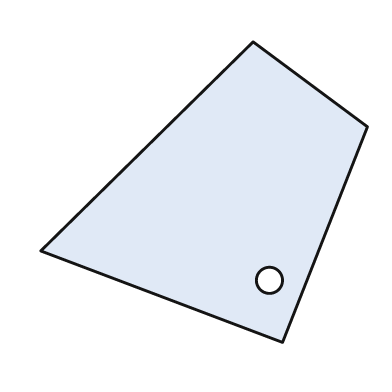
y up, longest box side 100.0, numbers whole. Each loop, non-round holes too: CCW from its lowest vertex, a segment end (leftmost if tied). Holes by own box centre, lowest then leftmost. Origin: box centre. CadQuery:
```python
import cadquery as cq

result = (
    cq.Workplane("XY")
    .moveTo(24.0, -46.0)
    .lineTo(50.0, 20.0)
    .lineTo(15.0, 46.0)
    .lineTo(-50.0, -18.0)
    .close()
    .moveTo(20.0, -27.0)
    .circle(4.0)
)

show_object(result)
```